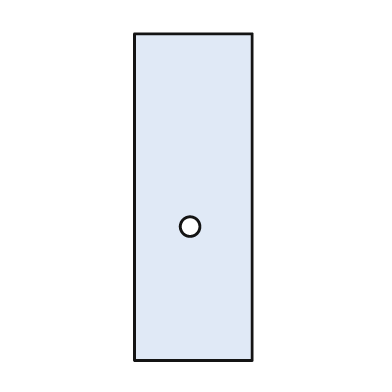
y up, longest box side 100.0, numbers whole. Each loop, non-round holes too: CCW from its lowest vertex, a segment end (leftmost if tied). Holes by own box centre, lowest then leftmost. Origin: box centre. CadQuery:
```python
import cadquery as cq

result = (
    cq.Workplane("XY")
    .moveTo(-18.0, -50.0)
    .lineTo(18.0, -50.0)
    .lineTo(18.0, 50.0)
    .lineTo(-18.0, 50.0)
    .close()
    .moveTo(-1.0, -9.0)
    .circle(3.0)
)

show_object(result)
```